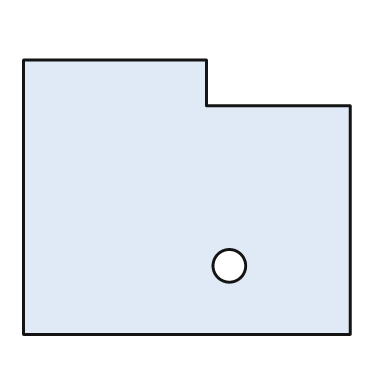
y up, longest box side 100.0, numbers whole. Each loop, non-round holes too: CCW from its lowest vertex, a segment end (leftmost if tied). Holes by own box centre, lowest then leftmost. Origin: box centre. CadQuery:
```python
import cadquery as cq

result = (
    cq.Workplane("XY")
    .moveTo(-50.0, -42.0)
    .lineTo(50.0, -42.0)
    .lineTo(50.0, 28.0)
    .lineTo(6.0, 28.0)
    .lineTo(6.0, 42.0)
    .lineTo(-50.0, 42.0)
    .close()
    .moveTo(13.0, -21.0)
    .circle(5.0)
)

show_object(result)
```